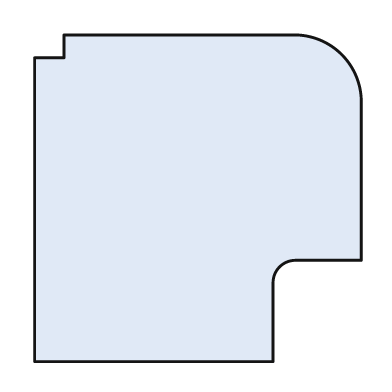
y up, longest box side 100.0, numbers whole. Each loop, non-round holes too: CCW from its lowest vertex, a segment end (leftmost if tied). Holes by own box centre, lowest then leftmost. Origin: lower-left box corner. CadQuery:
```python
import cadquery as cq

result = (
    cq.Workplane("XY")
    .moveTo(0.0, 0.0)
    .lineTo(73.0, 0.0)
    .lineTo(73.0, 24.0)
    .threePointArc((75.0, 29.0), (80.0, 31.0))
    .lineTo(100.0, 31.0)
    .lineTo(100.0, 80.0)
    .threePointArc((94.0, 94.0), (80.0, 100.0))
    .lineTo(9.0, 100.0)
    .lineTo(9.0, 93.0)
    .lineTo(0.0, 93.0)
    .close()
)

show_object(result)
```